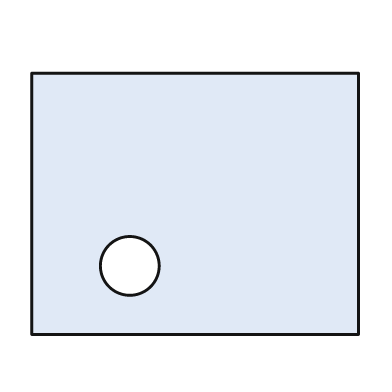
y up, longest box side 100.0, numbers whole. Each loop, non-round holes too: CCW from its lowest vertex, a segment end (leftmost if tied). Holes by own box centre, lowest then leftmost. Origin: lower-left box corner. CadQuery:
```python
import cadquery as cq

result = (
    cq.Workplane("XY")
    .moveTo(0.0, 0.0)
    .lineTo(100.0, 0.0)
    .lineTo(100.0, 80.0)
    .lineTo(0.0, 80.0)
    .close()
    .moveTo(30.0, 21.0)
    .circle(9.0)
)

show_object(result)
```